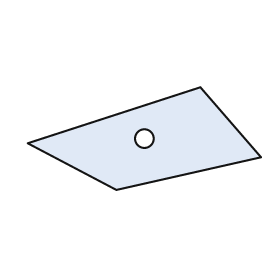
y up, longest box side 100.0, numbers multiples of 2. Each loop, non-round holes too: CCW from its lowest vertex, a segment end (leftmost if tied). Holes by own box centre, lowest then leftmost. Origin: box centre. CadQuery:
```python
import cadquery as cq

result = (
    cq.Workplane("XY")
    .moveTo(-12.0, -22.0)
    .lineTo(50.0, -8.0)
    .lineTo(24.0, 22.0)
    .lineTo(-50.0, -2.0)
    .close()
    .moveTo(0.0, 0.0)
    .circle(4.0)
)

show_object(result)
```